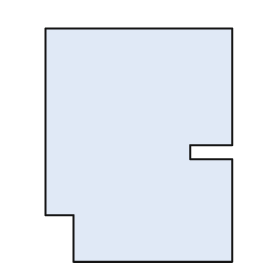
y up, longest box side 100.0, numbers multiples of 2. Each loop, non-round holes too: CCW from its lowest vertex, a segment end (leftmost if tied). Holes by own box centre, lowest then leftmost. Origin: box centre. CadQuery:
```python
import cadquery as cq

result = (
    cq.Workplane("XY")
    .moveTo(-28.0, -50.0)
    .lineTo(40.0, -50.0)
    .lineTo(40.0, -6.0)
    .lineTo(22.0, -6.0)
    .lineTo(22.0, 0.0)
    .lineTo(40.0, 0.0)
    .lineTo(40.0, 50.0)
    .lineTo(-40.0, 50.0)
    .lineTo(-40.0, -30.0)
    .lineTo(-28.0, -30.0)
    .close()
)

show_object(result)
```